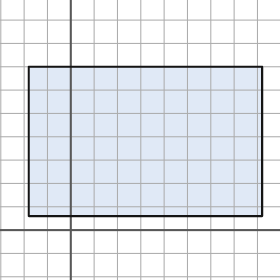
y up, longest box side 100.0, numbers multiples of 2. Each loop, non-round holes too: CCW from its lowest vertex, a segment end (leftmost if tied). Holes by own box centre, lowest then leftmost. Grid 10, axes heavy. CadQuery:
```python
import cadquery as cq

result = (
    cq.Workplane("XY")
    .moveTo(-18.0, 6.0)
    .lineTo(82.0, 6.0)
    .lineTo(82.0, 70.0)
    .lineTo(-18.0, 70.0)
    .close()
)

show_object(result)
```